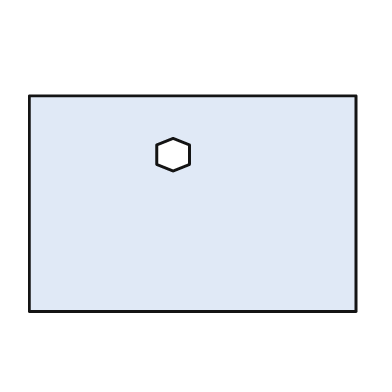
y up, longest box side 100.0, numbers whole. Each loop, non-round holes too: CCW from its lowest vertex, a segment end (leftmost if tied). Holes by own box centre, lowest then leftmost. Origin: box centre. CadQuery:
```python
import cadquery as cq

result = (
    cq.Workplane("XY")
    .moveTo(-50.0, -33.0)
    .lineTo(50.0, -33.0)
    .lineTo(50.0, 33.0)
    .lineTo(-50.0, 33.0)
    .close()
    .moveTo(-6.0, 10.0)
    .lineTo(-1.0, 12.0)
    .lineTo(-1.0, 18.0)
    .lineTo(-6.0, 20.0)
    .lineTo(-11.0, 18.0)
    .lineTo(-11.0, 12.0)
    .close()
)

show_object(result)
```